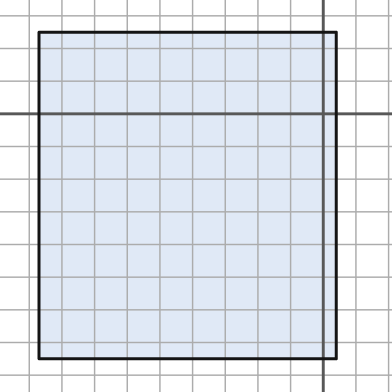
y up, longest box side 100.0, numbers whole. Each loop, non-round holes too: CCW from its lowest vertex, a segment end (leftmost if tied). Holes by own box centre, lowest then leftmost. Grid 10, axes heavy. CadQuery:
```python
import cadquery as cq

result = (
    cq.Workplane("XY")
    .moveTo(-87.0, -75.0)
    .lineTo(4.0, -75.0)
    .lineTo(4.0, 25.0)
    .lineTo(-87.0, 25.0)
    .close()
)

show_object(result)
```